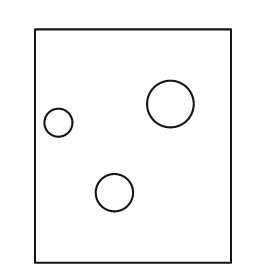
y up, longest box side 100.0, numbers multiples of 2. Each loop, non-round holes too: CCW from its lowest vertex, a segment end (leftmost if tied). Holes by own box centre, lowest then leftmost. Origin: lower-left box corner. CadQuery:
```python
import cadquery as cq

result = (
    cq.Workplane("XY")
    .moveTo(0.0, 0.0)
    .lineTo(84.0, 0.0)
    .lineTo(84.0, 100.0)
    .lineTo(0.0, 100.0)
    .close()
    .moveTo(34.0, 30.0)
    .circle(8.0)
    .moveTo(10.0, 60.0)
    .circle(6.0)
    .moveTo(58.0, 68.0)
    .circle(10.0)
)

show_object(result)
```